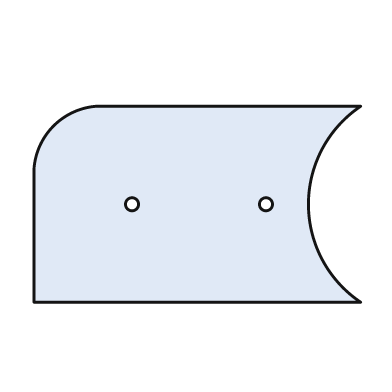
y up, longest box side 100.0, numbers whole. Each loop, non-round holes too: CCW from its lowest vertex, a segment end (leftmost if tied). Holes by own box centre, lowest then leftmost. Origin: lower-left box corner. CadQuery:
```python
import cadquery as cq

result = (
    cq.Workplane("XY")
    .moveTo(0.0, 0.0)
    .lineTo(100.0, 0.0)
    .threePointArc((84.0, 30.0), (100.0, 60.0))
    .lineTo(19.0, 60.0)
    .threePointArc((6.0, 54.0), (0.0, 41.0))
    .close()
    .moveTo(30.0, 30.0)
    .circle(2.0)
    .moveTo(71.0, 30.0)
    .circle(2.0)
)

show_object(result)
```